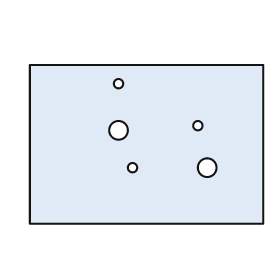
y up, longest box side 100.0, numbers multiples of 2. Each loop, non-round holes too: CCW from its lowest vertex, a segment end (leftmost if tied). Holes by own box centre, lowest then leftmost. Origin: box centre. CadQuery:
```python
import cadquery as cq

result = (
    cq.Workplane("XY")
    .moveTo(-50.0, -34.0)
    .lineTo(50.0, -34.0)
    .lineTo(50.0, 34.0)
    .lineTo(-50.0, 34.0)
    .close()
    .moveTo(-6.0, -10.0)
    .circle(2.0)
    .moveTo(26.0, -10.0)
    .circle(4.0)
    .moveTo(-12.0, 6.0)
    .circle(4.0)
    .moveTo(22.0, 8.0)
    .circle(2.0)
    .moveTo(-12.0, 26.0)
    .circle(2.0)
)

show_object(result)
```